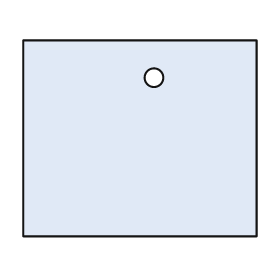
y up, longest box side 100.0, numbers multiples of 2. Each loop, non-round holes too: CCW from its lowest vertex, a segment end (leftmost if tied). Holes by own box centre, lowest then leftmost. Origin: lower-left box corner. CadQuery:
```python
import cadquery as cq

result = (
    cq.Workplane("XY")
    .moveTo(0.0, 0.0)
    .lineTo(100.0, 0.0)
    .lineTo(100.0, 84.0)
    .lineTo(0.0, 84.0)
    .close()
    .moveTo(56.0, 68.0)
    .circle(4.0)
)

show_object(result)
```